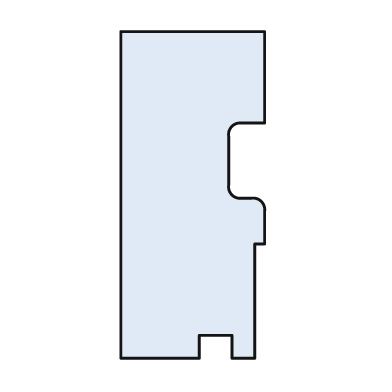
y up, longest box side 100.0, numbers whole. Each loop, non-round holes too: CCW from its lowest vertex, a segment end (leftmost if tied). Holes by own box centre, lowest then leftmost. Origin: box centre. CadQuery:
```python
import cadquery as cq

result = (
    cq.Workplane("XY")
    .moveTo(-22.0, -50.0)
    .lineTo(2.0, -50.0)
    .lineTo(2.0, -43.0)
    .lineTo(12.0, -43.0)
    .lineTo(12.0, -50.0)
    .lineTo(19.0, -50.0)
    .lineTo(19.0, -15.0)
    .lineTo(22.0, -15.0)
    .lineTo(22.0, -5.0)
    .threePointArc((21.0, -2.0), (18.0, -1.0))
    .lineTo(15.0, -1.0)
    .threePointArc((12.0, 0.0), (11.0, 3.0))
    .lineTo(11.0, 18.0)
    .threePointArc((12.0, 21.0), (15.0, 22.0))
    .lineTo(22.0, 22.0)
    .lineTo(22.0, 50.0)
    .lineTo(-22.0, 50.0)
    .close()
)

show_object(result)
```